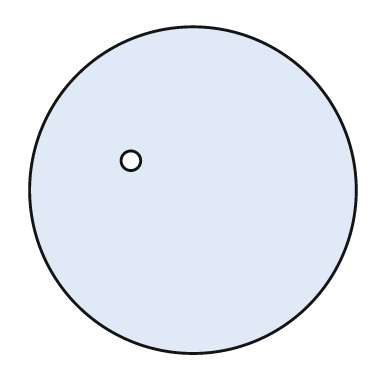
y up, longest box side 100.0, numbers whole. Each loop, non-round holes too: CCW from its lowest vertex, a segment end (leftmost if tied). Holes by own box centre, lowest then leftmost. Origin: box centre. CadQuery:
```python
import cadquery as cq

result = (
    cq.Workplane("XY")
    .moveTo(0.0, 0.0)
    .circle(50.0)
    .moveTo(-19.0, 9.0)
    .circle(3.0)
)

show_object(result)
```